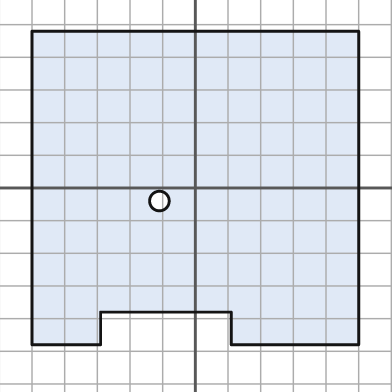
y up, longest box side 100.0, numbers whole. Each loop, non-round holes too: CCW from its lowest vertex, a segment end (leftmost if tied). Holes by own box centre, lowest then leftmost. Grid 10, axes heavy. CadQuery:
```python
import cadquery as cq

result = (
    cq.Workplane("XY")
    .moveTo(-50.0, -48.0)
    .lineTo(-29.0, -48.0)
    .lineTo(-29.0, -38.0)
    .lineTo(11.0, -38.0)
    .lineTo(11.0, -48.0)
    .lineTo(50.0, -48.0)
    .lineTo(50.0, 48.0)
    .lineTo(-50.0, 48.0)
    .close()
    .moveTo(-11.0, -4.0)
    .circle(3.0)
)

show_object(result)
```